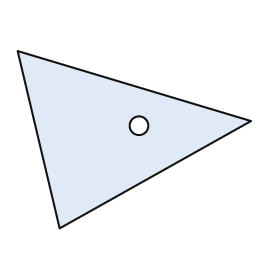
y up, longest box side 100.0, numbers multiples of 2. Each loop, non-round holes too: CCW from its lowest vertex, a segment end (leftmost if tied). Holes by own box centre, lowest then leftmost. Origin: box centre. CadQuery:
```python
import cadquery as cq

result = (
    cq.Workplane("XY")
    .moveTo(-32.0, -38.0)
    .lineTo(50.0, 8.0)
    .lineTo(-50.0, 38.0)
    .close()
    .moveTo(2.0, 6.0)
    .circle(4.0)
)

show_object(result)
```